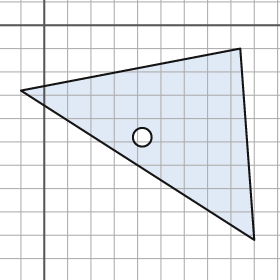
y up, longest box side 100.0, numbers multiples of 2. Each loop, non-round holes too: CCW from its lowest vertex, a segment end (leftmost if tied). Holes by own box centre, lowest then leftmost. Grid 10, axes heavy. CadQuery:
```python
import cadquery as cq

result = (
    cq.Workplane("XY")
    .moveTo(90.0, -92.0)
    .lineTo(84.0, -10.0)
    .lineTo(-10.0, -28.0)
    .close()
    .moveTo(42.0, -48.0)
    .circle(4.0)
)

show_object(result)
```